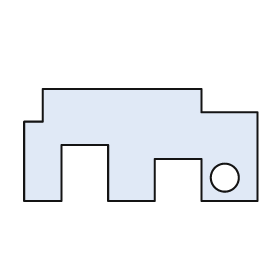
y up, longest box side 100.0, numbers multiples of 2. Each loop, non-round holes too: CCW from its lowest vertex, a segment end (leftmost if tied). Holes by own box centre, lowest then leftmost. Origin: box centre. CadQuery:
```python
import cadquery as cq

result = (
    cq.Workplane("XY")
    .moveTo(-50.0, -24.0)
    .lineTo(-34.0, -24.0)
    .lineTo(-34.0, 0.0)
    .lineTo(-14.0, 0.0)
    .lineTo(-14.0, -24.0)
    .lineTo(6.0, -24.0)
    .lineTo(6.0, -6.0)
    .lineTo(26.0, -6.0)
    .lineTo(26.0, -24.0)
    .lineTo(50.0, -24.0)
    .lineTo(50.0, 14.0)
    .lineTo(26.0, 14.0)
    .lineTo(26.0, 24.0)
    .lineTo(-42.0, 24.0)
    .lineTo(-42.0, 10.0)
    .lineTo(-50.0, 10.0)
    .close()
    .moveTo(36.0, -14.0)
    .circle(6.0)
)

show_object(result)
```